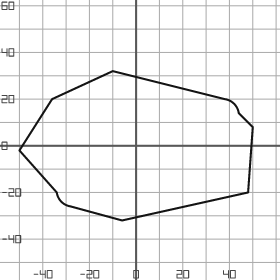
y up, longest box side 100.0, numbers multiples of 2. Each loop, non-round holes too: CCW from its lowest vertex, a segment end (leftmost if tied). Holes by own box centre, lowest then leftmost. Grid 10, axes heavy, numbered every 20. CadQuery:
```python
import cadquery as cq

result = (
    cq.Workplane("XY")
    .moveTo(-6.0, -32.0)
    .lineTo(48.0, -20.0)
    .lineTo(50.0, 8.0)
    .lineTo(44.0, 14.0)
    .threePointArc((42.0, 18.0), (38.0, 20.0))
    .lineTo(-10.0, 32.0)
    .lineTo(-36.0, 20.0)
    .lineTo(-50.0, -2.0)
    .lineTo(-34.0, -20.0)
    .threePointArc((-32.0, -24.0), (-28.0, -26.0))
    .close()
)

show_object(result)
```